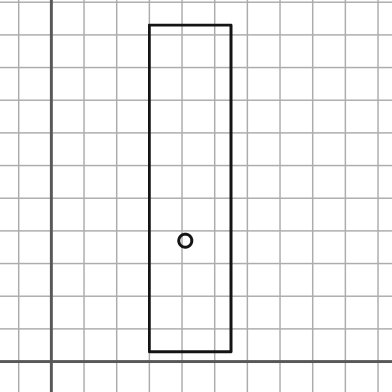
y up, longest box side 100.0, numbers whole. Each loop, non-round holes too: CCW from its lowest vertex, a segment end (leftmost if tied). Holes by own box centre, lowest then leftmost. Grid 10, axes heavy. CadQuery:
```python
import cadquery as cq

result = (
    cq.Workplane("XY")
    .moveTo(30.0, 3.0)
    .lineTo(55.0, 3.0)
    .lineTo(55.0, 103.0)
    .lineTo(30.0, 103.0)
    .close()
    .moveTo(41.0, 37.0)
    .circle(2.0)
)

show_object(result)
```